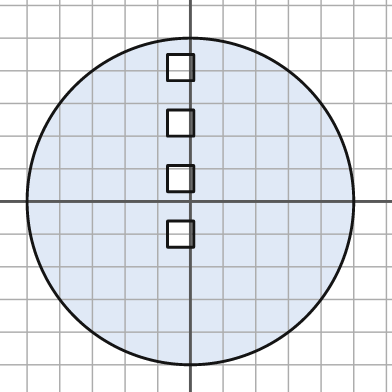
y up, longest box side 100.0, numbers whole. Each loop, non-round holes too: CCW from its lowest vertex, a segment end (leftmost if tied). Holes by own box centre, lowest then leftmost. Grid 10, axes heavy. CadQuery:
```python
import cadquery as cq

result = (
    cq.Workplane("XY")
    .moveTo(0.0, 0.0)
    .circle(50.0)
    .moveTo(-7.0, -14.0)
    .lineTo(1.0, -14.0)
    .lineTo(1.0, -6.0)
    .lineTo(-7.0, -6.0)
    .close()
    .moveTo(-7.0, 3.0)
    .lineTo(1.0, 3.0)
    .lineTo(1.0, 11.0)
    .lineTo(-7.0, 11.0)
    .close()
    .moveTo(-7.0, 20.0)
    .lineTo(1.0, 20.0)
    .lineTo(1.0, 28.0)
    .lineTo(-7.0, 28.0)
    .close()
    .moveTo(-7.0, 37.0)
    .lineTo(1.0, 37.0)
    .lineTo(1.0, 45.0)
    .lineTo(-7.0, 45.0)
    .close()
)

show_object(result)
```